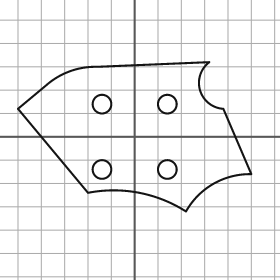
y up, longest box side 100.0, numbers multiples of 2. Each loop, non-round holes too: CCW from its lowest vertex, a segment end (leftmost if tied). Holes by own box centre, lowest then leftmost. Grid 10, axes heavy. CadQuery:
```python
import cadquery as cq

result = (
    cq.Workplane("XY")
    .moveTo(22.0, -32.0)
    .threePointArc((34.0, -20.0), (50.0, -16.0))
    .lineTo(38.0, 12.0)
    .threePointArc((28.0, 20.0), (32.0, 32.0))
    .lineTo(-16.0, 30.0)
    .threePointArc((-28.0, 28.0), (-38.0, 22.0))
    .lineTo(-50.0, 12.0)
    .lineTo(-20.0, -24.0)
    .threePointArc((2.0, -24.0), (22.0, -32.0))
    .close()
    .moveTo(-14.0, -14.0)
    .circle(4.0)
    .moveTo(14.0, -14.0)
    .circle(4.0)
    .moveTo(-14.0, 14.0)
    .circle(4.0)
    .moveTo(14.0, 14.0)
    .circle(4.0)
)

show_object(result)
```